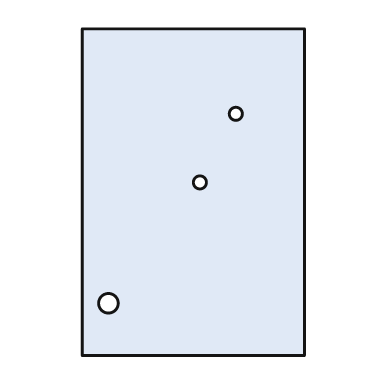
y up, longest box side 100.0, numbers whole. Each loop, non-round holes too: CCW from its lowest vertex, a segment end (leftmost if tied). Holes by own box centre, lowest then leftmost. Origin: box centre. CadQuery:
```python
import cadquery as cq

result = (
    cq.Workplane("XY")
    .moveTo(-34.0, -50.0)
    .lineTo(34.0, -50.0)
    .lineTo(34.0, 50.0)
    .lineTo(-34.0, 50.0)
    .close()
    .moveTo(-26.0, -34.0)
    .circle(3.0)
    .moveTo(2.0, 3.0)
    .circle(2.0)
    .moveTo(13.0, 24.0)
    .circle(2.0)
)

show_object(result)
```